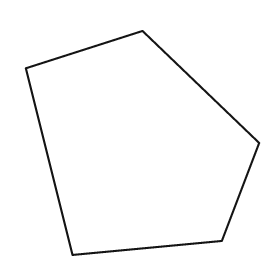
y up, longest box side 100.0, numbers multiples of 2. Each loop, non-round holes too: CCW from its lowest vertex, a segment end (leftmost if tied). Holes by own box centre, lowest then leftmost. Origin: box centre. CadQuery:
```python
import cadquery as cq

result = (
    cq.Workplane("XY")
    .moveTo(-30.0, -48.0)
    .lineTo(34.0, -42.0)
    .lineTo(50.0, 0.0)
    .lineTo(0.0, 48.0)
    .lineTo(-50.0, 32.0)
    .close()
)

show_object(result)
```